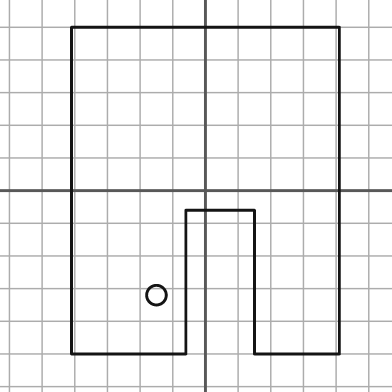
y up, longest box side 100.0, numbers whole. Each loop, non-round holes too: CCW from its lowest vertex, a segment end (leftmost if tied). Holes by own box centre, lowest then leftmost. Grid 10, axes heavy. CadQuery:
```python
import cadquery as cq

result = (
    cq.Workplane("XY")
    .moveTo(-41.0, -50.0)
    .lineTo(-6.0, -50.0)
    .lineTo(-6.0, -6.0)
    .lineTo(15.0, -6.0)
    .lineTo(15.0, -50.0)
    .lineTo(41.0, -50.0)
    .lineTo(41.0, 50.0)
    .lineTo(-41.0, 50.0)
    .close()
    .moveTo(-15.0, -32.0)
    .circle(3.0)
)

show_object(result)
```